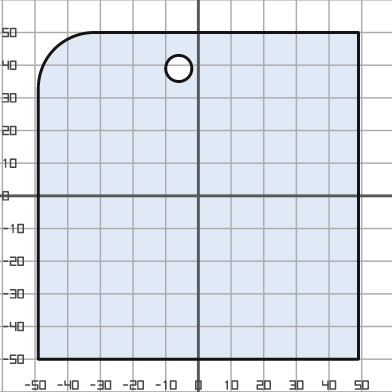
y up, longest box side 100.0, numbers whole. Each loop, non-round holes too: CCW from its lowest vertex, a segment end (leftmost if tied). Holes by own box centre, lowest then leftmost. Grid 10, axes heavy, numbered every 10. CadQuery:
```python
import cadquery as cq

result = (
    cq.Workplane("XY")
    .moveTo(-49.0, -50.0)
    .lineTo(49.0, -50.0)
    .lineTo(49.0, 50.0)
    .lineTo(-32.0, 50.0)
    .threePointArc((-44.0, 45.0), (-49.0, 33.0))
    .close()
    .moveTo(-6.0, 39.0)
    .circle(4.0)
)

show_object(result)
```